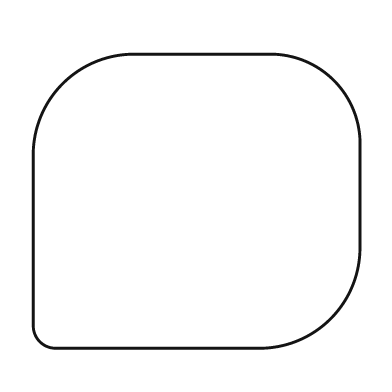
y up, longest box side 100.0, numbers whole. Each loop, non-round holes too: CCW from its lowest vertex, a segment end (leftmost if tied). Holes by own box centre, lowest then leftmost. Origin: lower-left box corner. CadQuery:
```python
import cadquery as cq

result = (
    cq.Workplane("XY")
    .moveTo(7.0, 0.0)
    .lineTo(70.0, 0.0)
    .threePointArc((91.0, 9.0), (100.0, 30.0))
    .lineTo(100.0, 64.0)
    .threePointArc((92.0, 82.0), (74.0, 90.0))
    .lineTo(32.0, 90.0)
    .threePointArc((9.0, 81.0), (0.0, 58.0))
    .lineTo(0.0, 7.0)
    .threePointArc((2.0, 2.0), (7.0, 0.0))
    .close()
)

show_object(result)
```